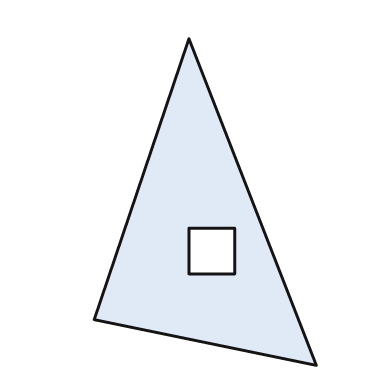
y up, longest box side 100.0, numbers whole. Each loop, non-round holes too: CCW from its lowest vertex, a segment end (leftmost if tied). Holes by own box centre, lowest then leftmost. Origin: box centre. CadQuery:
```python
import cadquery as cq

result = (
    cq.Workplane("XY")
    .moveTo(34.0, -50.0)
    .lineTo(-5.0, 50.0)
    .lineTo(-34.0, -36.0)
    .close()
    .moveTo(-5.0, -22.0)
    .lineTo(9.0, -22.0)
    .lineTo(9.0, -8.0)
    .lineTo(-5.0, -8.0)
    .close()
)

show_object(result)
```